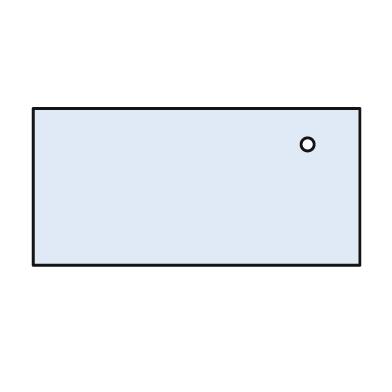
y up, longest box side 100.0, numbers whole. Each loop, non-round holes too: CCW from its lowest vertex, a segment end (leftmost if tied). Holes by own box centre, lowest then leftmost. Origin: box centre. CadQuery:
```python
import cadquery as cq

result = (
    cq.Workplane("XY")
    .moveTo(-50.0, -24.0)
    .lineTo(50.0, -24.0)
    .lineTo(50.0, 24.0)
    .lineTo(-50.0, 24.0)
    .close()
    .moveTo(34.0, 13.0)
    .circle(2.0)
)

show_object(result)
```